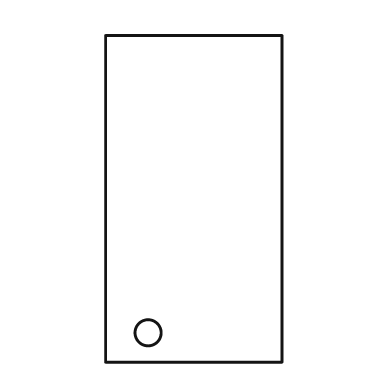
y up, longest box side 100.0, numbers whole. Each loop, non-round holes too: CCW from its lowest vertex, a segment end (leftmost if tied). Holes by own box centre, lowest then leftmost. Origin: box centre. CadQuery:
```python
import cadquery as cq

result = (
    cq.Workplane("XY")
    .moveTo(-27.0, -50.0)
    .lineTo(27.0, -50.0)
    .lineTo(27.0, 50.0)
    .lineTo(-27.0, 50.0)
    .close()
    .moveTo(-14.0, -41.0)
    .circle(4.0)
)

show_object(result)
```